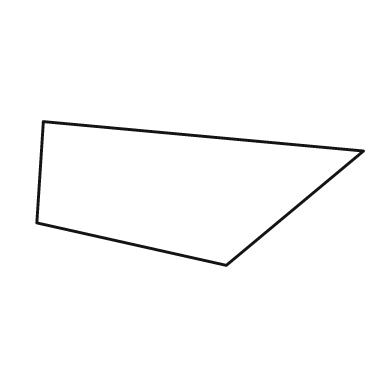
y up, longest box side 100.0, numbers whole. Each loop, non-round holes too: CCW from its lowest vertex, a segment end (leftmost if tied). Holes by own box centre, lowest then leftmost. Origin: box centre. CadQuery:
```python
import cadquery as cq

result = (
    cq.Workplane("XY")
    .moveTo(8.0, -22.0)
    .lineTo(50.0, 13.0)
    .lineTo(-48.0, 22.0)
    .lineTo(-50.0, -9.0)
    .close()
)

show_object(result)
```